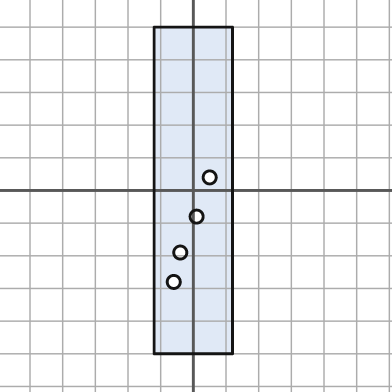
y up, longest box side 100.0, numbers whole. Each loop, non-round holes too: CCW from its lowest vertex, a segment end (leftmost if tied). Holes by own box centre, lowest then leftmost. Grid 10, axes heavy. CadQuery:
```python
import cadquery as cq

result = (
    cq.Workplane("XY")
    .moveTo(-12.0, -50.0)
    .lineTo(12.0, -50.0)
    .lineTo(12.0, 50.0)
    .lineTo(-12.0, 50.0)
    .close()
    .moveTo(-6.0, -28.0)
    .circle(2.0)
    .moveTo(-4.0, -19.0)
    .circle(2.0)
    .moveTo(1.0, -8.0)
    .circle(2.0)
    .moveTo(5.0, 4.0)
    .circle(2.0)
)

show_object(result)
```